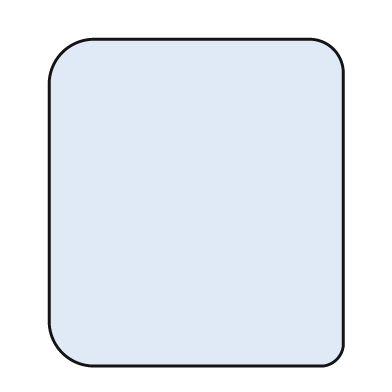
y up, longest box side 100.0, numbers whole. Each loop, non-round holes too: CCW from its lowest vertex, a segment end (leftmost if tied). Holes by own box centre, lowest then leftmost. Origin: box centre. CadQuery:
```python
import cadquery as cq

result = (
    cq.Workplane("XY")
    .moveTo(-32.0, -50.0)
    .lineTo(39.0, -50.0)
    .threePointArc((43.0, -48.0), (45.0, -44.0))
    .lineTo(45.0, 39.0)
    .threePointArc((42.0, 47.0), (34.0, 50.0))
    .lineTo(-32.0, 50.0)
    .threePointArc((-41.0, 46.0), (-45.0, 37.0))
    .lineTo(-45.0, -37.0)
    .threePointArc((-41.0, -46.0), (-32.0, -50.0))
    .close()
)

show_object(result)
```